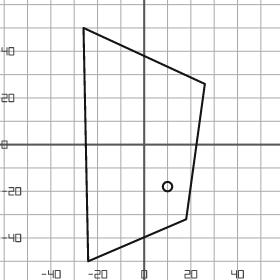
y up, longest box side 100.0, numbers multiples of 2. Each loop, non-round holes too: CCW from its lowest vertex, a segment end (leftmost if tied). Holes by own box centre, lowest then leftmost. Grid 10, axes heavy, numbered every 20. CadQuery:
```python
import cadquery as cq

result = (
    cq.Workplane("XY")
    .moveTo(-24.0, -50.0)
    .lineTo(18.0, -32.0)
    .lineTo(26.0, 26.0)
    .lineTo(-26.0, 50.0)
    .close()
    .moveTo(10.0, -18.0)
    .circle(2.0)
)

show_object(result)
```